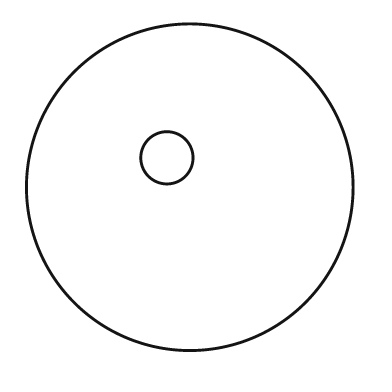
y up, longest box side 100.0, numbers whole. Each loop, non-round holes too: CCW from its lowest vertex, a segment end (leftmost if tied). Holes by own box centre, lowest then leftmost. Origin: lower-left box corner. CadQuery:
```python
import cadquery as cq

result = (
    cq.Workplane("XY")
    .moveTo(50.0, 50.0)
    .circle(50.0)
    .moveTo(43.0, 59.0)
    .circle(8.0)
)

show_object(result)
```